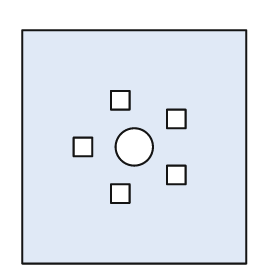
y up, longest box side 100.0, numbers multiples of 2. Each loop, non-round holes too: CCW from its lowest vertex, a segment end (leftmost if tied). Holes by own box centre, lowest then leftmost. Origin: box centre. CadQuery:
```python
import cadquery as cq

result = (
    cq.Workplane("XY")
    .moveTo(-48.0, -50.0)
    .lineTo(48.0, -50.0)
    .lineTo(48.0, 50.0)
    .lineTo(-48.0, 50.0)
    .close()
    .moveTo(-10.0, -24.0)
    .lineTo(-2.0, -24.0)
    .lineTo(-2.0, -16.0)
    .lineTo(-10.0, -16.0)
    .close()
    .moveTo(14.0, -16.0)
    .lineTo(22.0, -16.0)
    .lineTo(22.0, -8.0)
    .lineTo(14.0, -8.0)
    .close()
    .moveTo(-26.0, -4.0)
    .lineTo(-18.0, -4.0)
    .lineTo(-18.0, 4.0)
    .lineTo(-26.0, 4.0)
    .close()
    .moveTo(0.0, 0.0)
    .circle(8.0)
    .moveTo(14.0, 8.0)
    .lineTo(22.0, 8.0)
    .lineTo(22.0, 16.0)
    .lineTo(14.0, 16.0)
    .close()
    .moveTo(-10.0, 16.0)
    .lineTo(-2.0, 16.0)
    .lineTo(-2.0, 24.0)
    .lineTo(-10.0, 24.0)
    .close()
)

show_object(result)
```